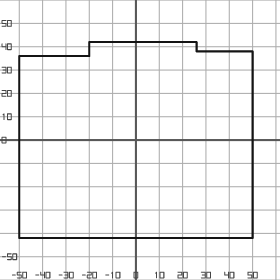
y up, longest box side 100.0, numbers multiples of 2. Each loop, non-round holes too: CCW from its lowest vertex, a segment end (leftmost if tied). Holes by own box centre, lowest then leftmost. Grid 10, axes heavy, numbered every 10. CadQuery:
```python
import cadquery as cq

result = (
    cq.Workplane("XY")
    .moveTo(-50.0, -42.0)
    .lineTo(50.0, -42.0)
    .lineTo(50.0, 38.0)
    .lineTo(26.0, 38.0)
    .lineTo(26.0, 42.0)
    .lineTo(-20.0, 42.0)
    .lineTo(-20.0, 36.0)
    .lineTo(-50.0, 36.0)
    .close()
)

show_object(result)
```